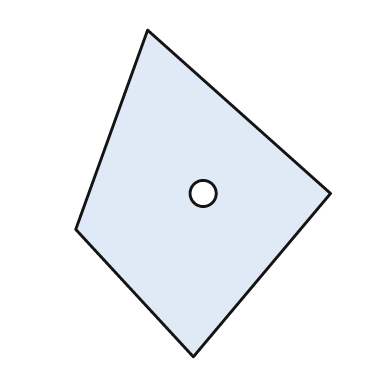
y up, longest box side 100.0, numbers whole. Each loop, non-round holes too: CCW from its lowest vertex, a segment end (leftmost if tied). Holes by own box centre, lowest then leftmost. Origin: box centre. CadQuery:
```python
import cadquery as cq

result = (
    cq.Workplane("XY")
    .moveTo(-3.0, -50.0)
    .lineTo(39.0, 0.0)
    .lineTo(-17.0, 50.0)
    .lineTo(-39.0, -11.0)
    .close()
    .moveTo(0.0, 0.0)
    .circle(4.0)
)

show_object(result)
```